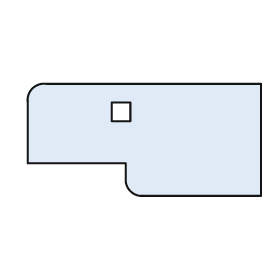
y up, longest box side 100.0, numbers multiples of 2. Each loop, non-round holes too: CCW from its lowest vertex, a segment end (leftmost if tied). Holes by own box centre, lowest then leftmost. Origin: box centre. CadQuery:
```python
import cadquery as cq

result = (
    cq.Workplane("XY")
    .moveTo(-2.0, -24.0)
    .lineTo(50.0, -24.0)
    .lineTo(50.0, 24.0)
    .lineTo(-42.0, 24.0)
    .threePointArc((-48.0, 22.0), (-50.0, 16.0))
    .lineTo(-50.0, -10.0)
    .lineTo(-8.0, -10.0)
    .lineTo(-8.0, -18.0)
    .threePointArc((-6.0, -22.0), (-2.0, -24.0))
    .close()
    .moveTo(-14.0, 8.0)
    .lineTo(-6.0, 8.0)
    .lineTo(-6.0, 16.0)
    .lineTo(-14.0, 16.0)
    .close()
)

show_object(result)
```